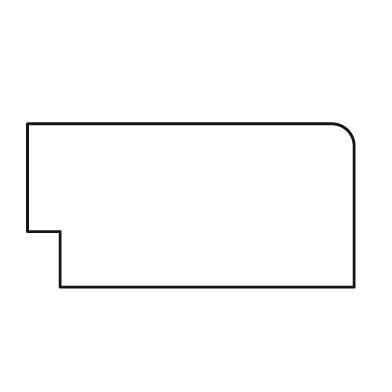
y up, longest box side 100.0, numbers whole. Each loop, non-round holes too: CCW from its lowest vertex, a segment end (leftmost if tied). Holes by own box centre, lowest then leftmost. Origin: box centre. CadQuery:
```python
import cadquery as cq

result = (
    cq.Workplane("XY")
    .moveTo(-40.0, -25.0)
    .lineTo(50.0, -25.0)
    .lineTo(50.0, 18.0)
    .threePointArc((48.0, 23.0), (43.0, 25.0))
    .lineTo(-50.0, 25.0)
    .lineTo(-50.0, -8.0)
    .lineTo(-40.0, -8.0)
    .close()
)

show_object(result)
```